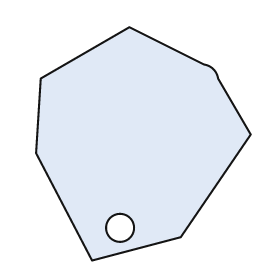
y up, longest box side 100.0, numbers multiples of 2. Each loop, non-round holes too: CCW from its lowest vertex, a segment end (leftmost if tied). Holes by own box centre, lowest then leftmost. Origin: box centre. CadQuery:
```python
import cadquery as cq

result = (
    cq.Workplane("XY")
    .moveTo(-22.0, -50.0)
    .lineTo(16.0, -40.0)
    .lineTo(46.0, 4.0)
    .lineTo(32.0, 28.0)
    .threePointArc((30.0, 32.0), (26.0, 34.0))
    .lineTo(-6.0, 50.0)
    .lineTo(-44.0, 28.0)
    .lineTo(-46.0, -4.0)
    .close()
    .moveTo(-10.0, -36.0)
    .circle(6.0)
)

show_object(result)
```